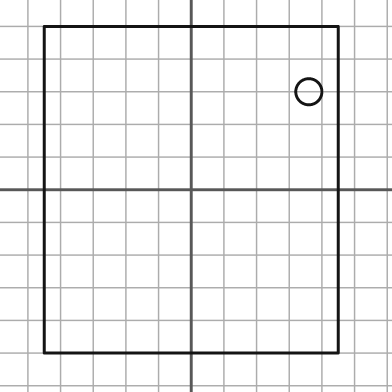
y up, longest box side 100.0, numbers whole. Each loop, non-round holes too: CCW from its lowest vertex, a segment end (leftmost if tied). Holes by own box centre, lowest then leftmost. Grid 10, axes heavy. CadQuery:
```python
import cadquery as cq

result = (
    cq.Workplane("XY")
    .moveTo(-45.0, -50.0)
    .lineTo(45.0, -50.0)
    .lineTo(45.0, 50.0)
    .lineTo(-45.0, 50.0)
    .close()
    .moveTo(36.0, 30.0)
    .circle(4.0)
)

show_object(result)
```